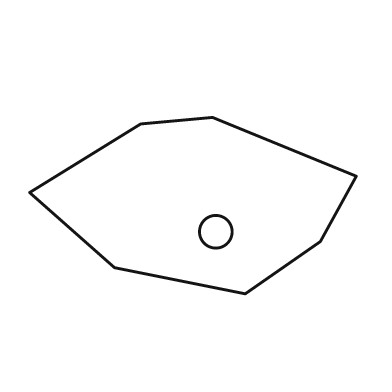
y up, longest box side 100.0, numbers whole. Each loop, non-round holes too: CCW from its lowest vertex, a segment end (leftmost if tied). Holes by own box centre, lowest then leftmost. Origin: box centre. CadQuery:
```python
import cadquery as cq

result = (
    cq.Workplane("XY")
    .moveTo(16.0, -27.0)
    .lineTo(39.0, -11.0)
    .lineTo(50.0, 9.0)
    .lineTo(6.0, 27.0)
    .lineTo(-16.0, 25.0)
    .lineTo(-50.0, 4.0)
    .lineTo(-24.0, -19.0)
    .close()
    .moveTo(7.0, -8.0)
    .circle(5.0)
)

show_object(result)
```